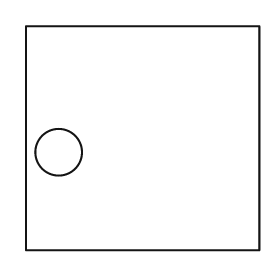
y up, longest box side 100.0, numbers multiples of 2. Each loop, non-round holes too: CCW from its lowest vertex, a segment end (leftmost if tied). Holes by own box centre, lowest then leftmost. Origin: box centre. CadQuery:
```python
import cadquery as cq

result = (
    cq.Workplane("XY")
    .moveTo(-50.0, -48.0)
    .lineTo(50.0, -48.0)
    .lineTo(50.0, 48.0)
    .lineTo(-50.0, 48.0)
    .close()
    .moveTo(-36.0, -6.0)
    .circle(10.0)
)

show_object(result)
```